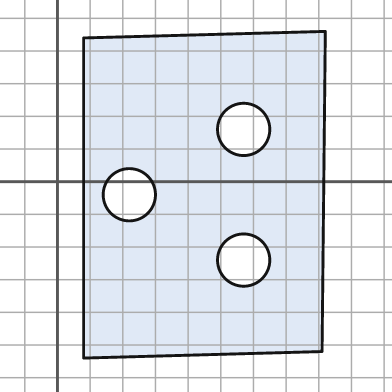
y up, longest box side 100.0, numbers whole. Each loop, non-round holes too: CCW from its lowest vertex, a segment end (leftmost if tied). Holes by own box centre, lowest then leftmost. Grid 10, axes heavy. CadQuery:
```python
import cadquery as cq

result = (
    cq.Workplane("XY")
    .moveTo(8.0, -54.0)
    .lineTo(81.0, -52.0)
    .lineTo(82.0, 46.0)
    .lineTo(8.0, 44.0)
    .close()
    .moveTo(57.0, -24.0)
    .circle(8.0)
    .moveTo(22.0, -4.0)
    .circle(8.0)
    .moveTo(57.0, 16.0)
    .circle(8.0)
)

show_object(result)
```